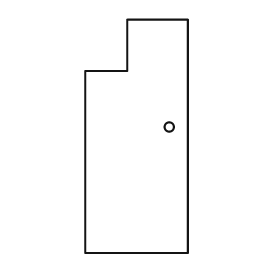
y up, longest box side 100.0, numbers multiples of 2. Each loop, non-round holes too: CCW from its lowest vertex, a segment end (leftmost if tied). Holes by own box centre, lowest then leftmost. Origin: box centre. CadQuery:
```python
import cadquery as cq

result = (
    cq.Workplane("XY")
    .moveTo(-22.0, -50.0)
    .lineTo(22.0, -50.0)
    .lineTo(22.0, 50.0)
    .lineTo(-4.0, 50.0)
    .lineTo(-4.0, 28.0)
    .lineTo(-22.0, 28.0)
    .close()
    .moveTo(14.0, 4.0)
    .circle(2.0)
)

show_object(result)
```